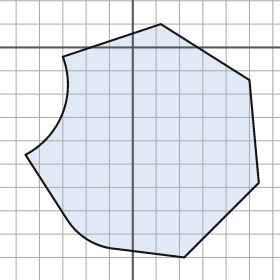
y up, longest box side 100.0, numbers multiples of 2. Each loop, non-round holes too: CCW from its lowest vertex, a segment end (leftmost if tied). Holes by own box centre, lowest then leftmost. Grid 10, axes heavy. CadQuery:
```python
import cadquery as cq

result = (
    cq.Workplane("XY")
    .moveTo(22.0, -90.0)
    .lineTo(54.0, -58.0)
    .lineTo(50.0, -14.0)
    .lineTo(12.0, 10.0)
    .lineTo(-30.0, -4.0)
    .threePointArc((-30.0, -28.0), (-46.0, -46.0))
    .lineTo(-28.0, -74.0)
    .threePointArc((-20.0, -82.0), (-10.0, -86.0))
    .close()
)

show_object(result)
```